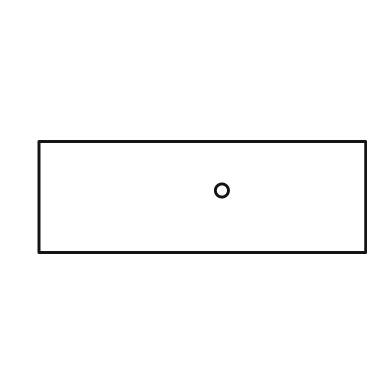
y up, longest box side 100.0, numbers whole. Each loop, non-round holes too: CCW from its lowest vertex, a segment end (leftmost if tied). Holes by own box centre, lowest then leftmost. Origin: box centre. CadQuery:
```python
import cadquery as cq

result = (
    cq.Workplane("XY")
    .moveTo(-50.0, -17.0)
    .lineTo(50.0, -17.0)
    .lineTo(50.0, 17.0)
    .lineTo(-50.0, 17.0)
    .close()
    .moveTo(6.0, 2.0)
    .circle(2.0)
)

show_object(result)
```